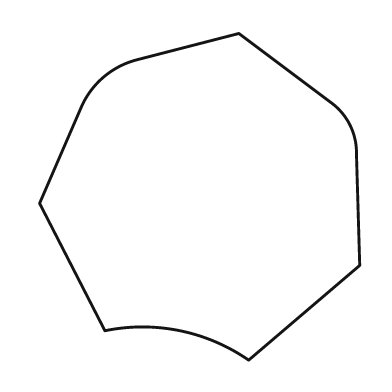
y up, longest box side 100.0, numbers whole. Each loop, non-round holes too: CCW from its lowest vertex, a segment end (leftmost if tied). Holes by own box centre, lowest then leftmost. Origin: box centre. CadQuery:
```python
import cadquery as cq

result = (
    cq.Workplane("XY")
    .moveTo(15.0, -50.0)
    .lineTo(49.0, -21.0)
    .lineTo(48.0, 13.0)
    .threePointArc((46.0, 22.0), (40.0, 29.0))
    .lineTo(12.0, 50.0)
    .lineTo(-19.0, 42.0)
    .threePointArc((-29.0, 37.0), (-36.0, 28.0))
    .lineTo(-49.0, -2.0)
    .lineTo(-29.0, -41.0)
    .threePointArc((-6.0, -41.0), (15.0, -50.0))
    .close()
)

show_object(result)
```